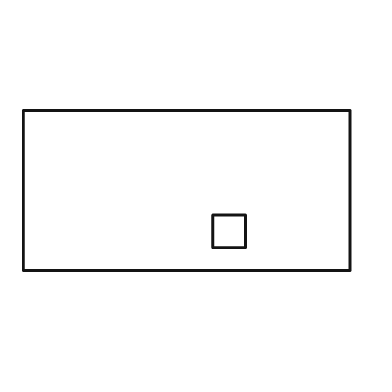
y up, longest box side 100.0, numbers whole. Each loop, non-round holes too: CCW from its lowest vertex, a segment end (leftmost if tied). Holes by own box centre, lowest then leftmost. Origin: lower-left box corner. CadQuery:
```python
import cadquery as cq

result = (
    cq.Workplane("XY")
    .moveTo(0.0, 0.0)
    .lineTo(100.0, 0.0)
    .lineTo(100.0, 49.0)
    .lineTo(0.0, 49.0)
    .close()
    .moveTo(58.0, 7.0)
    .lineTo(68.0, 7.0)
    .lineTo(68.0, 17.0)
    .lineTo(58.0, 17.0)
    .close()
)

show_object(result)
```